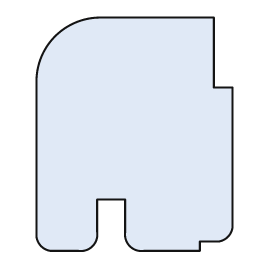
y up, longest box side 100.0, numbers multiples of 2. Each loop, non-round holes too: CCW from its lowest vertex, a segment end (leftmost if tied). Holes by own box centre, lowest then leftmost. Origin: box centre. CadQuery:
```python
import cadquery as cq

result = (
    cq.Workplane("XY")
    .moveTo(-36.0, -50.0)
    .lineTo(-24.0, -50.0)
    .threePointArc((-18.0, -48.0), (-16.0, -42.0))
    .lineTo(-16.0, -28.0)
    .lineTo(-4.0, -28.0)
    .lineTo(-4.0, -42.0)
    .threePointArc((-2.0, -48.0), (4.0, -50.0))
    .lineTo(28.0, -50.0)
    .lineTo(28.0, -46.0)
    .lineTo(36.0, -46.0)
    .threePointArc((40.0, -44.0), (42.0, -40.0))
    .lineTo(42.0, 20.0)
    .lineTo(34.0, 20.0)
    .lineTo(34.0, 50.0)
    .lineTo(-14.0, 50.0)
    .threePointArc((-34.0, 42.0), (-42.0, 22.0))
    .lineTo(-42.0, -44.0)
    .threePointArc((-40.0, -48.0), (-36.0, -50.0))
    .close()
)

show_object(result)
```